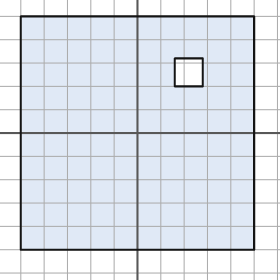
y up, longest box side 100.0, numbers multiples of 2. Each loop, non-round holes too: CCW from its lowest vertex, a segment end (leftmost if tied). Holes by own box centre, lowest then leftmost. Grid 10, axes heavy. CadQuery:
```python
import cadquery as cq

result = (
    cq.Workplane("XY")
    .moveTo(-50.0, -50.0)
    .lineTo(50.0, -50.0)
    .lineTo(50.0, 50.0)
    .lineTo(-50.0, 50.0)
    .close()
    .moveTo(16.0, 20.0)
    .lineTo(28.0, 20.0)
    .lineTo(28.0, 32.0)
    .lineTo(16.0, 32.0)
    .close()
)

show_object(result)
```